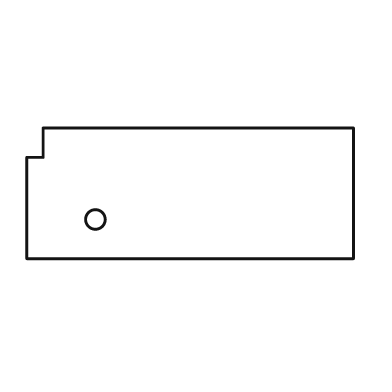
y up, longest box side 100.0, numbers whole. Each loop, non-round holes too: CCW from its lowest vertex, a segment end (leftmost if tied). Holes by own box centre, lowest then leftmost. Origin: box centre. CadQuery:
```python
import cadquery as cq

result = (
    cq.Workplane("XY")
    .moveTo(-50.0, -20.0)
    .lineTo(50.0, -20.0)
    .lineTo(50.0, 20.0)
    .lineTo(-45.0, 20.0)
    .lineTo(-45.0, 11.0)
    .lineTo(-50.0, 11.0)
    .close()
    .moveTo(-29.0, -8.0)
    .circle(3.0)
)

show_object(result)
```